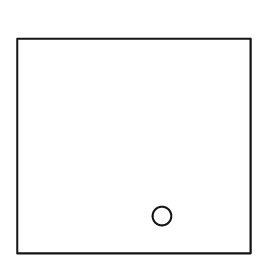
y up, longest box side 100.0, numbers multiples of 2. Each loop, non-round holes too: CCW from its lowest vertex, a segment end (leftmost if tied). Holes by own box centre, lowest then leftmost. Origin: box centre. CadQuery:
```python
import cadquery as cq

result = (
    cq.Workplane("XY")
    .moveTo(-50.0, -46.0)
    .lineTo(50.0, -46.0)
    .lineTo(50.0, 46.0)
    .lineTo(-50.0, 46.0)
    .close()
    .moveTo(12.0, -30.0)
    .circle(4.0)
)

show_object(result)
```